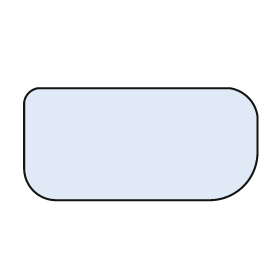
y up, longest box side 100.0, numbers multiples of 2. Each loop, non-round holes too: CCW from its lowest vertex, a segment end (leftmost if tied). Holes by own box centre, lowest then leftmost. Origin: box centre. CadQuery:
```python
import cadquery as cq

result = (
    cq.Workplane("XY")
    .moveTo(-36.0, -24.0)
    .lineTo(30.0, -24.0)
    .threePointArc((44.0, -18.0), (50.0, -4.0))
    .lineTo(50.0, 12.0)
    .threePointArc((46.0, 20.0), (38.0, 24.0))
    .lineTo(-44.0, 24.0)
    .threePointArc((-48.0, 22.0), (-50.0, 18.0))
    .lineTo(-50.0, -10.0)
    .threePointArc((-46.0, -20.0), (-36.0, -24.0))
    .close()
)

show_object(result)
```